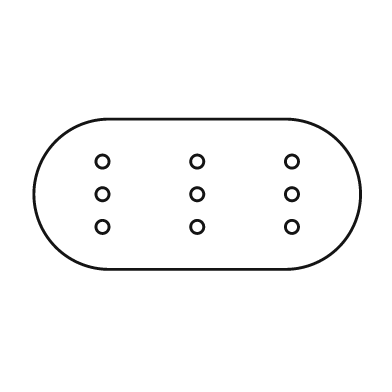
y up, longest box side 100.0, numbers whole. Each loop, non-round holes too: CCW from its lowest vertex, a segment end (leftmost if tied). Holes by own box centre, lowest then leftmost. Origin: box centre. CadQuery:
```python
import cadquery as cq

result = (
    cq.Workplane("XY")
    .moveTo(-27.0, -23.0)
    .lineTo(27.0, -23.0)
    .threePointArc((50.0, 0.0), (27.0, 23.0))
    .lineTo(-27.0, 23.0)
    .threePointArc((-50.0, 0.0), (-27.0, -23.0))
    .close()
    .moveTo(-29.0, -10.0)
    .circle(2.0)
    .moveTo(0.0, -10.0)
    .circle(2.0)
    .moveTo(29.0, -10.0)
    .circle(2.0)
    .moveTo(-29.0, 0.0)
    .circle(2.0)
    .moveTo(0.0, 0.0)
    .circle(2.0)
    .moveTo(29.0, 0.0)
    .circle(2.0)
    .moveTo(-29.0, 10.0)
    .circle(2.0)
    .moveTo(0.0, 10.0)
    .circle(2.0)
    .moveTo(29.0, 10.0)
    .circle(2.0)
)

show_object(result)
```